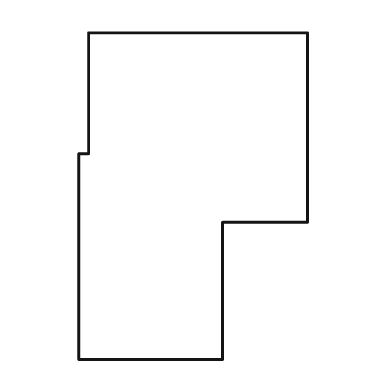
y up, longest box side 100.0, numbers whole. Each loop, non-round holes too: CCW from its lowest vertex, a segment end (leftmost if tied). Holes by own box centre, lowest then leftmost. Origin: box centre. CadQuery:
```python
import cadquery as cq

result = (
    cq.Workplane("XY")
    .moveTo(-35.0, -50.0)
    .lineTo(9.0, -50.0)
    .lineTo(9.0, -8.0)
    .lineTo(35.0, -8.0)
    .lineTo(35.0, 50.0)
    .lineTo(-32.0, 50.0)
    .lineTo(-32.0, 13.0)
    .lineTo(-35.0, 13.0)
    .close()
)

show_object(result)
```